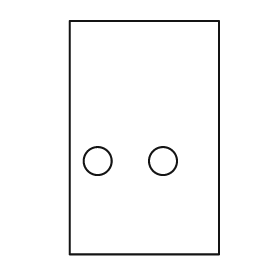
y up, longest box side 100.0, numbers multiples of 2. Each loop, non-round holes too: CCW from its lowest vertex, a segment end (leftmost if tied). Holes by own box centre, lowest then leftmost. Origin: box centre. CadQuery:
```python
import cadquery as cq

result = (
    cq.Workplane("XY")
    .moveTo(-32.0, -50.0)
    .lineTo(32.0, -50.0)
    .lineTo(32.0, 50.0)
    .lineTo(-32.0, 50.0)
    .close()
    .moveTo(-20.0, -10.0)
    .circle(6.0)
    .moveTo(8.0, -10.0)
    .circle(6.0)
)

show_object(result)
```